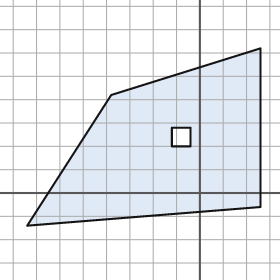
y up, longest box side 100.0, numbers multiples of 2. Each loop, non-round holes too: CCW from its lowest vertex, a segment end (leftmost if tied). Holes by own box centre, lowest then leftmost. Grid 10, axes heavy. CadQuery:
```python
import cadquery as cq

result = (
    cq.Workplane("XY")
    .moveTo(-74.0, -14.0)
    .lineTo(26.0, -6.0)
    .lineTo(26.0, 62.0)
    .lineTo(-38.0, 42.0)
    .close()
    .moveTo(-12.0, 20.0)
    .lineTo(-4.0, 20.0)
    .lineTo(-4.0, 28.0)
    .lineTo(-12.0, 28.0)
    .close()
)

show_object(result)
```